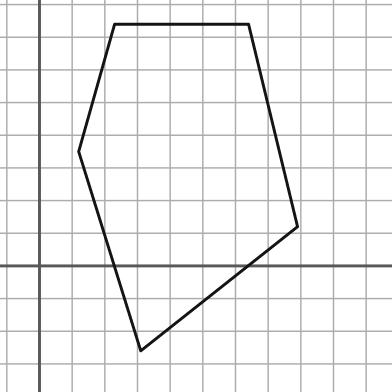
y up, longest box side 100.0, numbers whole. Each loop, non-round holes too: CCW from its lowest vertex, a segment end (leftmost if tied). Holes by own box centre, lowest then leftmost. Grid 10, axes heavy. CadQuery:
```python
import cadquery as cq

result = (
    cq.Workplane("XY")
    .moveTo(31.0, -26.0)
    .lineTo(79.0, 12.0)
    .lineTo(64.0, 74.0)
    .lineTo(23.0, 74.0)
    .lineTo(12.0, 35.0)
    .close()
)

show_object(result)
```